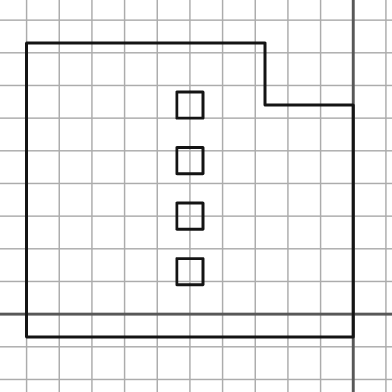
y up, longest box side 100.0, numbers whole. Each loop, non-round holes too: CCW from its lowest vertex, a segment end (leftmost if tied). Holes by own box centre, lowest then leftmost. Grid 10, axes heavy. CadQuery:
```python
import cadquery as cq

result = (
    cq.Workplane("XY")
    .moveTo(-100.0, -7.0)
    .lineTo(0.0, -7.0)
    .lineTo(0.0, 64.0)
    .lineTo(-27.0, 64.0)
    .lineTo(-27.0, 83.0)
    .lineTo(-100.0, 83.0)
    .close()
    .moveTo(-54.0, 9.0)
    .lineTo(-46.0, 9.0)
    .lineTo(-46.0, 17.0)
    .lineTo(-54.0, 17.0)
    .close()
    .moveTo(-54.0, 26.0)
    .lineTo(-46.0, 26.0)
    .lineTo(-46.0, 34.0)
    .lineTo(-54.0, 34.0)
    .close()
    .moveTo(-54.0, 43.0)
    .lineTo(-46.0, 43.0)
    .lineTo(-46.0, 51.0)
    .lineTo(-54.0, 51.0)
    .close()
    .moveTo(-54.0, 60.0)
    .lineTo(-46.0, 60.0)
    .lineTo(-46.0, 68.0)
    .lineTo(-54.0, 68.0)
    .close()
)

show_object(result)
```